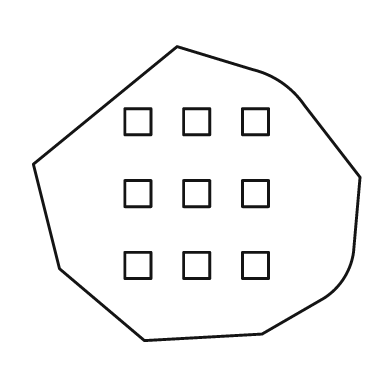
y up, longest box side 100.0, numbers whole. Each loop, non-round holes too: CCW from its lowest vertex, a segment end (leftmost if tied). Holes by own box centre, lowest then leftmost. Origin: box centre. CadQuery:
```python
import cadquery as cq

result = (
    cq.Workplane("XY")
    .moveTo(-16.0, -45.0)
    .lineTo(20.0, -43.0)
    .lineTo(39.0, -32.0)
    .threePointArc((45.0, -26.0), (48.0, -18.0))
    .lineTo(50.0, 5.0)
    .lineTo(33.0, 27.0)
    .threePointArc((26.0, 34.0), (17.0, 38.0))
    .lineTo(-6.0, 45.0)
    .lineTo(-50.0, 9.0)
    .lineTo(-42.0, -23.0)
    .close()
    .moveTo(-22.0, -26.0)
    .lineTo(-14.0, -26.0)
    .lineTo(-14.0, -18.0)
    .lineTo(-22.0, -18.0)
    .close()
    .moveTo(-4.0, -26.0)
    .lineTo(4.0, -26.0)
    .lineTo(4.0, -18.0)
    .lineTo(-4.0, -18.0)
    .close()
    .moveTo(14.0, -26.0)
    .lineTo(22.0, -26.0)
    .lineTo(22.0, -18.0)
    .lineTo(14.0, -18.0)
    .close()
    .moveTo(-22.0, -4.0)
    .lineTo(-14.0, -4.0)
    .lineTo(-14.0, 4.0)
    .lineTo(-22.0, 4.0)
    .close()
    .moveTo(-4.0, -4.0)
    .lineTo(4.0, -4.0)
    .lineTo(4.0, 4.0)
    .lineTo(-4.0, 4.0)
    .close()
    .moveTo(14.0, -4.0)
    .lineTo(22.0, -4.0)
    .lineTo(22.0, 4.0)
    .lineTo(14.0, 4.0)
    .close()
    .moveTo(-22.0, 18.0)
    .lineTo(-14.0, 18.0)
    .lineTo(-14.0, 26.0)
    .lineTo(-22.0, 26.0)
    .close()
    .moveTo(-4.0, 18.0)
    .lineTo(4.0, 18.0)
    .lineTo(4.0, 26.0)
    .lineTo(-4.0, 26.0)
    .close()
    .moveTo(14.0, 18.0)
    .lineTo(22.0, 18.0)
    .lineTo(22.0, 26.0)
    .lineTo(14.0, 26.0)
    .close()
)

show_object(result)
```